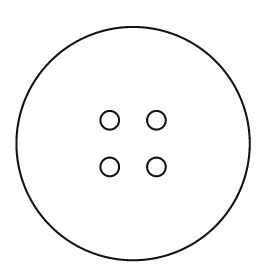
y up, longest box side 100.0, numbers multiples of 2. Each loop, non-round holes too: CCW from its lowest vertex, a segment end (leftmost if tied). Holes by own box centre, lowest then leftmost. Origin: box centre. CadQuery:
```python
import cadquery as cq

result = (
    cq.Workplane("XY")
    .moveTo(0.0, 0.0)
    .circle(50.0)
    .moveTo(-10.0, -10.0)
    .circle(4.0)
    .moveTo(10.0, -10.0)
    .circle(4.0)
    .moveTo(-10.0, 10.0)
    .circle(4.0)
    .moveTo(10.0, 10.0)
    .circle(4.0)
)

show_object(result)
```